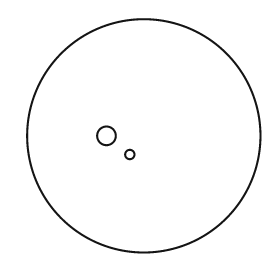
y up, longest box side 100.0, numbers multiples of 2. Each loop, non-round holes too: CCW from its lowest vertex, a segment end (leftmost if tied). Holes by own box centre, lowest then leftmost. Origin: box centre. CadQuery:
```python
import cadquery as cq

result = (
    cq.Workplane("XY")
    .moveTo(0.0, 0.0)
    .circle(50.0)
    .moveTo(-6.0, -8.0)
    .circle(2.0)
    .moveTo(-16.0, 0.0)
    .circle(4.0)
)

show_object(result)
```